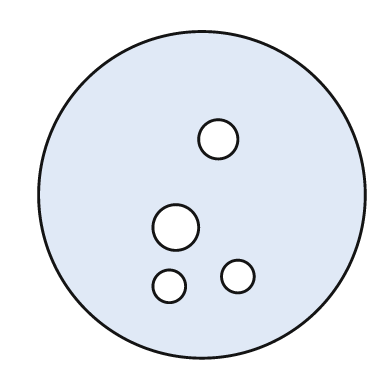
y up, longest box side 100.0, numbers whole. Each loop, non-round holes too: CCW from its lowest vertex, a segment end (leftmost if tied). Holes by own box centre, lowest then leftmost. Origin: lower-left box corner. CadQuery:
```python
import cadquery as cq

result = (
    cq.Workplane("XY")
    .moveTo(50.0, 50.0)
    .circle(50.0)
    .moveTo(40.0, 22.0)
    .circle(5.0)
    .moveTo(61.0, 25.0)
    .circle(5.0)
    .moveTo(42.0, 40.0)
    .circle(7.0)
    .moveTo(55.0, 67.0)
    .circle(6.0)
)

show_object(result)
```